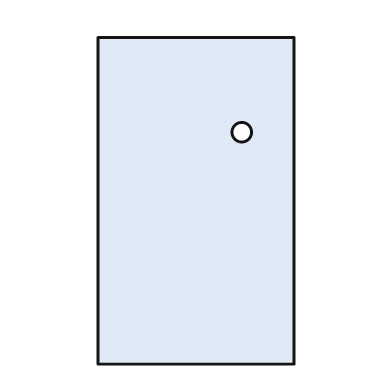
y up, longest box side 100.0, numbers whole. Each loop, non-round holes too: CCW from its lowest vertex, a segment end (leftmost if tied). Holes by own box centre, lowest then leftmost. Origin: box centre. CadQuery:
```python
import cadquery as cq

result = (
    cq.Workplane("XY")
    .moveTo(-30.0, -50.0)
    .lineTo(30.0, -50.0)
    .lineTo(30.0, 50.0)
    .lineTo(-30.0, 50.0)
    .close()
    .moveTo(14.0, 21.0)
    .circle(3.0)
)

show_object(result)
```